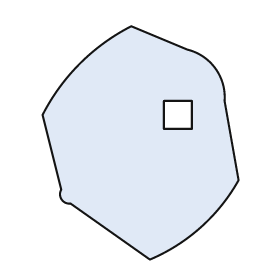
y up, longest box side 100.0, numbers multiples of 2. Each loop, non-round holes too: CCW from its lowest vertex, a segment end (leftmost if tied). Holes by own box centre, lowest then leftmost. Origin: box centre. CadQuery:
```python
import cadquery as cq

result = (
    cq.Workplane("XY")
    .moveTo(4.0, -50.0)
    .threePointArc((26.0, -36.0), (42.0, -16.0))
    .lineTo(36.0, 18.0)
    .threePointArc((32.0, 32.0), (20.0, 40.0))
    .lineTo(-4.0, 50.0)
    .threePointArc((-26.0, 34.0), (-42.0, 12.0))
    .lineTo(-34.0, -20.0)
    .threePointArc((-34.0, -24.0), (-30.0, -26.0))
    .close()
    .moveTo(10.0, 6.0)
    .lineTo(22.0, 6.0)
    .lineTo(22.0, 18.0)
    .lineTo(10.0, 18.0)
    .close()
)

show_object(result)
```